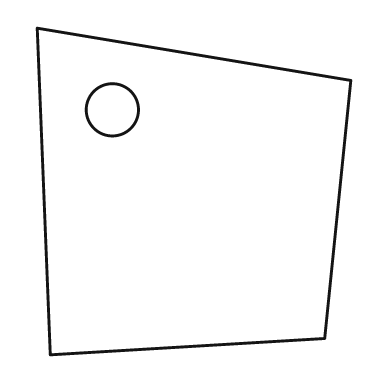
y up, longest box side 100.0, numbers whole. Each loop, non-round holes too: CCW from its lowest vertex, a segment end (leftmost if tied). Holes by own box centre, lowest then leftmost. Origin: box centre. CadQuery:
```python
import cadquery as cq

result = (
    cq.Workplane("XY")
    .moveTo(-44.0, -50.0)
    .lineTo(40.0, -45.0)
    .lineTo(48.0, 34.0)
    .lineTo(-48.0, 50.0)
    .close()
    .moveTo(-25.0, 25.0)
    .circle(8.0)
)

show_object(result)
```